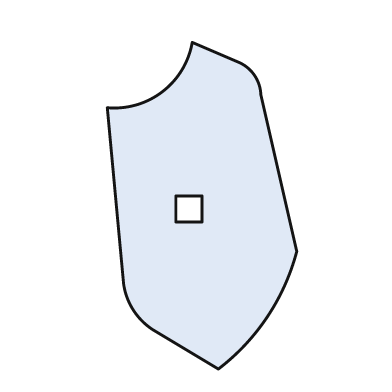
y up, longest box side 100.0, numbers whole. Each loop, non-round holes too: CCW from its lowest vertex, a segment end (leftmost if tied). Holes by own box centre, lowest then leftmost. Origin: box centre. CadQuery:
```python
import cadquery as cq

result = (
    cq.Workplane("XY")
    .moveTo(5.0, -50.0)
    .threePointArc((20.0, -34.0), (29.0, -14.0))
    .lineTo(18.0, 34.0)
    .threePointArc((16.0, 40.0), (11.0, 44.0))
    .lineTo(-3.0, 50.0)
    .threePointArc((-12.0, 35.0), (-29.0, 30.0))
    .lineTo(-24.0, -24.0)
    .threePointArc((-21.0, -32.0), (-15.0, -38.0))
    .close()
    .moveTo(-8.0, -5.0)
    .lineTo(0.0, -5.0)
    .lineTo(0.0, 3.0)
    .lineTo(-8.0, 3.0)
    .close()
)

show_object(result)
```